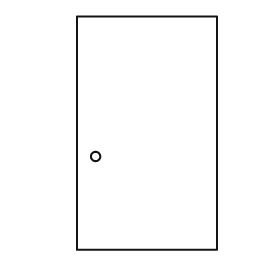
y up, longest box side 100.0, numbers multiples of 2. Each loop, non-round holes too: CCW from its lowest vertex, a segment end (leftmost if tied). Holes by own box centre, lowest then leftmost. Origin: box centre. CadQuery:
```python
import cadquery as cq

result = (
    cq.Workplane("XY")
    .moveTo(-30.0, -50.0)
    .lineTo(30.0, -50.0)
    .lineTo(30.0, 50.0)
    .lineTo(-30.0, 50.0)
    .close()
    .moveTo(-22.0, -10.0)
    .circle(2.0)
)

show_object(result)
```